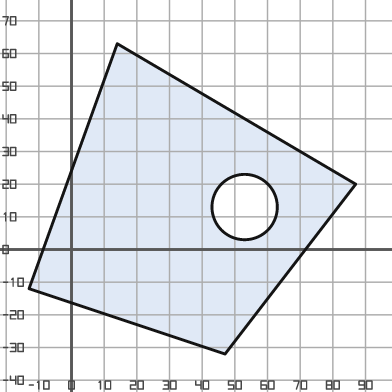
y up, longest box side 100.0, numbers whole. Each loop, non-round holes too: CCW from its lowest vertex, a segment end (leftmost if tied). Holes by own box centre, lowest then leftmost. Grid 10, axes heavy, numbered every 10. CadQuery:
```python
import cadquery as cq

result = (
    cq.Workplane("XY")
    .moveTo(47.0, -32.0)
    .lineTo(87.0, 20.0)
    .lineTo(14.0, 63.0)
    .lineTo(-13.0, -12.0)
    .close()
    .moveTo(53.0, 13.0)
    .circle(10.0)
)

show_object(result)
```